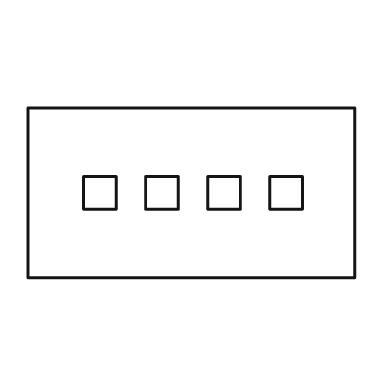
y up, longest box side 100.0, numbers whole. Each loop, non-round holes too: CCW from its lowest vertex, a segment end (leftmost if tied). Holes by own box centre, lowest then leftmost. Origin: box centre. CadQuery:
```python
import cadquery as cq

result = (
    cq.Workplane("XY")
    .moveTo(-50.0, -26.0)
    .lineTo(50.0, -26.0)
    .lineTo(50.0, 26.0)
    .lineTo(-50.0, 26.0)
    .close()
    .moveTo(-33.0, -5.0)
    .lineTo(-23.0, -5.0)
    .lineTo(-23.0, 5.0)
    .lineTo(-33.0, 5.0)
    .close()
    .moveTo(-14.0, -5.0)
    .lineTo(-4.0, -5.0)
    .lineTo(-4.0, 5.0)
    .lineTo(-14.0, 5.0)
    .close()
    .moveTo(5.0, -5.0)
    .lineTo(15.0, -5.0)
    .lineTo(15.0, 5.0)
    .lineTo(5.0, 5.0)
    .close()
    .moveTo(24.0, -5.0)
    .lineTo(34.0, -5.0)
    .lineTo(34.0, 5.0)
    .lineTo(24.0, 5.0)
    .close()
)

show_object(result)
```